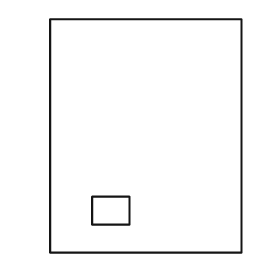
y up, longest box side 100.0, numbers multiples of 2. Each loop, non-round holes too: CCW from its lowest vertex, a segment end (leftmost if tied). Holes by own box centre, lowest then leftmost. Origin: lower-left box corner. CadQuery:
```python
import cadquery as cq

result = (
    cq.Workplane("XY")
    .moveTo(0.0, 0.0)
    .lineTo(82.0, 0.0)
    .lineTo(82.0, 100.0)
    .lineTo(0.0, 100.0)
    .close()
    .moveTo(18.0, 12.0)
    .lineTo(34.0, 12.0)
    .lineTo(34.0, 24.0)
    .lineTo(18.0, 24.0)
    .close()
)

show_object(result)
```